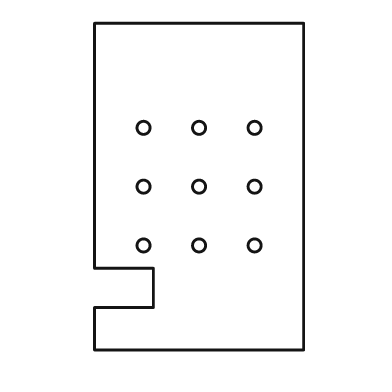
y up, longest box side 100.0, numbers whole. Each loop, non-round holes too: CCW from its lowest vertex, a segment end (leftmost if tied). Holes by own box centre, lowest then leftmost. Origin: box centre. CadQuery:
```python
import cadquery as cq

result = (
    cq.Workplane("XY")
    .moveTo(-32.0, -50.0)
    .lineTo(32.0, -50.0)
    .lineTo(32.0, 50.0)
    .lineTo(-32.0, 50.0)
    .lineTo(-32.0, -25.0)
    .lineTo(-14.0, -25.0)
    .lineTo(-14.0, -37.0)
    .lineTo(-32.0, -37.0)
    .close()
    .moveTo(-17.0, -18.0)
    .circle(2.0)
    .moveTo(0.0, -18.0)
    .circle(2.0)
    .moveTo(17.0, -18.0)
    .circle(2.0)
    .moveTo(-17.0, 0.0)
    .circle(2.0)
    .moveTo(0.0, 0.0)
    .circle(2.0)
    .moveTo(17.0, 0.0)
    .circle(2.0)
    .moveTo(-17.0, 18.0)
    .circle(2.0)
    .moveTo(0.0, 18.0)
    .circle(2.0)
    .moveTo(17.0, 18.0)
    .circle(2.0)
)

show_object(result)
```